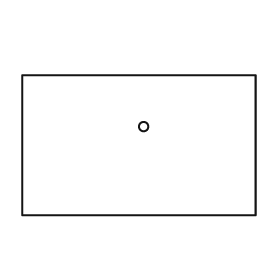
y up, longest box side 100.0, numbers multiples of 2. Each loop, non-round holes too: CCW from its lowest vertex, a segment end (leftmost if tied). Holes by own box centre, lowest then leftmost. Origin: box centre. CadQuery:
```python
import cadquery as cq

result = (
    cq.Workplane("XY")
    .moveTo(-50.0, -30.0)
    .lineTo(50.0, -30.0)
    .lineTo(50.0, 30.0)
    .lineTo(-50.0, 30.0)
    .close()
    .moveTo(2.0, 8.0)
    .circle(2.0)
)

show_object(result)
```